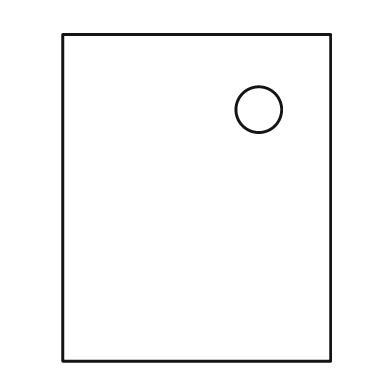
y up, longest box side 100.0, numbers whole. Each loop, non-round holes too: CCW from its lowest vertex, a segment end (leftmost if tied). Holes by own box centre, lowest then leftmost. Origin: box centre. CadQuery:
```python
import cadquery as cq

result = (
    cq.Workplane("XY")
    .moveTo(-41.0, -50.0)
    .lineTo(41.0, -50.0)
    .lineTo(41.0, 50.0)
    .lineTo(-41.0, 50.0)
    .close()
    .moveTo(19.0, 27.0)
    .circle(7.0)
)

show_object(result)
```